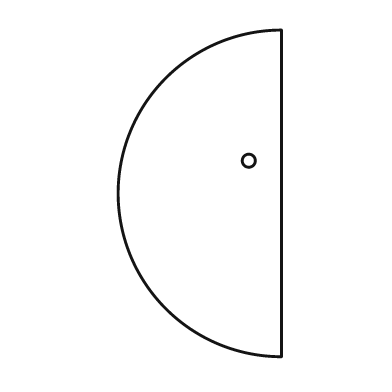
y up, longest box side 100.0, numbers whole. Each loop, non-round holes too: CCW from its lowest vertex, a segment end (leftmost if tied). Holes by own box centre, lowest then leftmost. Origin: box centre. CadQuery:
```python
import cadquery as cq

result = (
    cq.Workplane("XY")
    .moveTo(25.0, -50.0)
    .lineTo(25.0, 50.0)
    .threePointArc((-25.0, 0.0), (25.0, -50.0))
    .close()
    .moveTo(15.0, 10.0)
    .circle(2.0)
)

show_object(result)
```